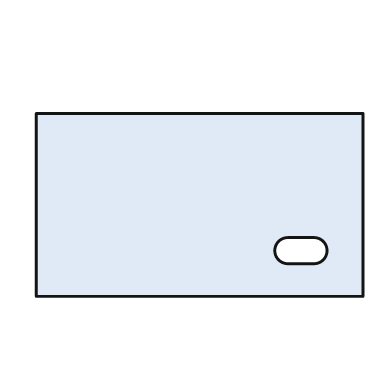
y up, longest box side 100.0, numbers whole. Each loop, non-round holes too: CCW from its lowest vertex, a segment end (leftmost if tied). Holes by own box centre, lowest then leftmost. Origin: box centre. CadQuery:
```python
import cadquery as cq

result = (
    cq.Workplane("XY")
    .moveTo(-50.0, -28.0)
    .lineTo(50.0, -28.0)
    .lineTo(50.0, 28.0)
    .lineTo(-50.0, 28.0)
    .close()
    .moveTo(27.0, -18.0)
    .lineTo(35.0, -18.0)
    .threePointArc((39.0, -14.0), (35.0, -10.0))
    .lineTo(27.0, -10.0)
    .threePointArc((23.0, -14.0), (27.0, -18.0))
    .close()
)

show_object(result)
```